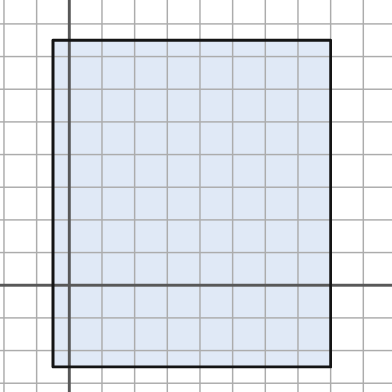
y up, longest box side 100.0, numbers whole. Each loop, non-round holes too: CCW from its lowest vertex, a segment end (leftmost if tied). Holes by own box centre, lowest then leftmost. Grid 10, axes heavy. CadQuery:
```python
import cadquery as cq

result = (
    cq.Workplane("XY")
    .moveTo(-5.0, -25.0)
    .lineTo(80.0, -25.0)
    .lineTo(80.0, 75.0)
    .lineTo(-5.0, 75.0)
    .close()
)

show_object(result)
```